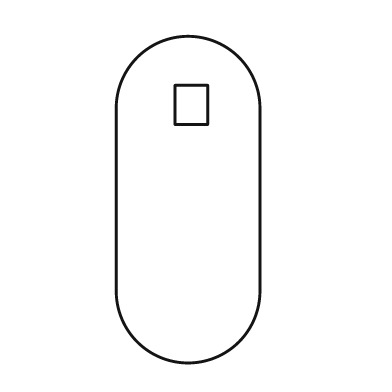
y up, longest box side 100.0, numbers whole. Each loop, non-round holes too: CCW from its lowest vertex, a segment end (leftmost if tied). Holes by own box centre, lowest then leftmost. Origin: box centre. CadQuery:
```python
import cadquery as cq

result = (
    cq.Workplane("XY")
    .moveTo(-22.0, -28.0)
    .threePointArc((0.0, -50.0), (22.0, -28.0))
    .lineTo(22.0, 28.0)
    .threePointArc((0.0, 50.0), (-22.0, 28.0))
    .close()
    .moveTo(-4.0, 23.0)
    .lineTo(6.0, 23.0)
    .lineTo(6.0, 35.0)
    .lineTo(-4.0, 35.0)
    .close()
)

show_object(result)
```